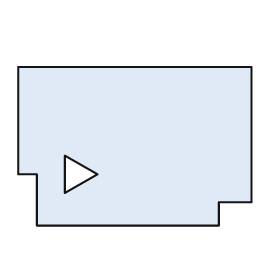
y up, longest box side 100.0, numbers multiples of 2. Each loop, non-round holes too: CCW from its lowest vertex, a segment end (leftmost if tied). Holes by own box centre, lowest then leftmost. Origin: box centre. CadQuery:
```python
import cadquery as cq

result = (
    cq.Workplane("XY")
    .moveTo(-42.0, -34.0)
    .lineTo(36.0, -34.0)
    .lineTo(36.0, -24.0)
    .lineTo(50.0, -24.0)
    .lineTo(50.0, 34.0)
    .lineTo(-50.0, 34.0)
    .lineTo(-50.0, -12.0)
    .lineTo(-42.0, -12.0)
    .close()
    .moveTo(-30.0, -20.0)
    .lineTo(-16.0, -12.0)
    .lineTo(-30.0, -4.0)
    .close()
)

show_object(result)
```